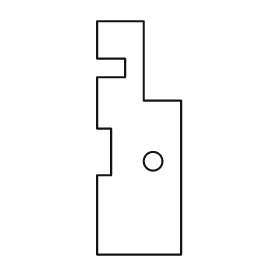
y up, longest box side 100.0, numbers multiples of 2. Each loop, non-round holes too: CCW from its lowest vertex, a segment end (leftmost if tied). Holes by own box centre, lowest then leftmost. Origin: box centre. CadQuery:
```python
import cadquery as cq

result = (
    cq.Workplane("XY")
    .moveTo(-18.0, -50.0)
    .lineTo(18.0, -50.0)
    .lineTo(18.0, 16.0)
    .lineTo(2.0, 16.0)
    .lineTo(2.0, 50.0)
    .lineTo(-18.0, 50.0)
    .lineTo(-18.0, 34.0)
    .lineTo(-6.0, 34.0)
    .lineTo(-6.0, 26.0)
    .lineTo(-18.0, 26.0)
    .lineTo(-18.0, 4.0)
    .lineTo(-12.0, 4.0)
    .lineTo(-12.0, -16.0)
    .lineTo(-18.0, -16.0)
    .close()
    .moveTo(6.0, -10.0)
    .circle(4.0)
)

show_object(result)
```